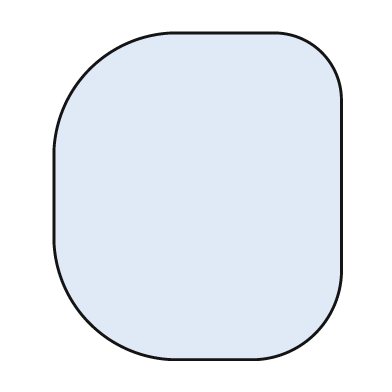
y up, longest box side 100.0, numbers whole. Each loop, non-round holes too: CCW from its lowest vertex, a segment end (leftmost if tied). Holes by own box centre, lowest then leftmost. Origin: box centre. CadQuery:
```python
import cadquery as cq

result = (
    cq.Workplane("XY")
    .moveTo(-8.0, -50.0)
    .lineTo(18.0, -50.0)
    .threePointArc((36.0, -42.0), (44.0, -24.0))
    .lineTo(44.0, 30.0)
    .threePointArc((38.0, 44.0), (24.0, 50.0))
    .lineTo(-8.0, 50.0)
    .threePointArc((-33.0, 39.0), (-44.0, 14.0))
    .lineTo(-44.0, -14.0)
    .threePointArc((-33.0, -39.0), (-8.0, -50.0))
    .close()
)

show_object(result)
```